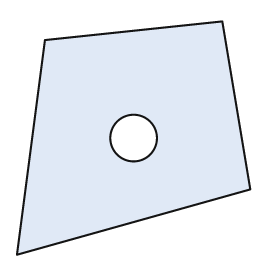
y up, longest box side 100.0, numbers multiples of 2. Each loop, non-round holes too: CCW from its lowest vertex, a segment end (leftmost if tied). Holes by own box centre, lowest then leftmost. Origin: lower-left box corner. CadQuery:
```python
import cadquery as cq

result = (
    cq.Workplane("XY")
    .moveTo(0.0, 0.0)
    .lineTo(100.0, 28.0)
    .lineTo(88.0, 100.0)
    .lineTo(12.0, 92.0)
    .close()
    .moveTo(50.0, 50.0)
    .circle(10.0)
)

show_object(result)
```